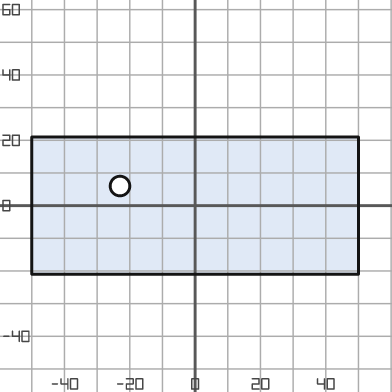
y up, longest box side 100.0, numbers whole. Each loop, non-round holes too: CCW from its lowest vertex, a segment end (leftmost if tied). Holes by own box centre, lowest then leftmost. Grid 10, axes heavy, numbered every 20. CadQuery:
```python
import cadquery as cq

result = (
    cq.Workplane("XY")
    .moveTo(-50.0, -21.0)
    .lineTo(50.0, -21.0)
    .lineTo(50.0, 21.0)
    .lineTo(-50.0, 21.0)
    .close()
    .moveTo(-23.0, 6.0)
    .circle(3.0)
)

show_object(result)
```